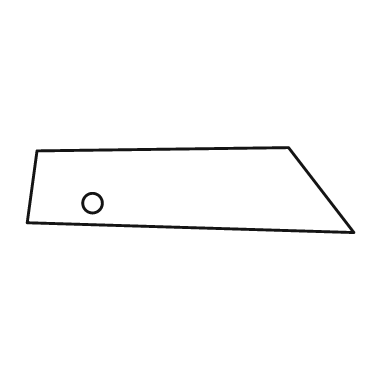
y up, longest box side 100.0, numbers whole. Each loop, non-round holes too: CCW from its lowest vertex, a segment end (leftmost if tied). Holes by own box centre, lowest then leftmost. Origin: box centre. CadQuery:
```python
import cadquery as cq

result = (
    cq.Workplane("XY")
    .moveTo(50.0, -13.0)
    .lineTo(30.0, 13.0)
    .lineTo(-47.0, 12.0)
    .lineTo(-50.0, -10.0)
    .close()
    .moveTo(-30.0, -4.0)
    .circle(3.0)
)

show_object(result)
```